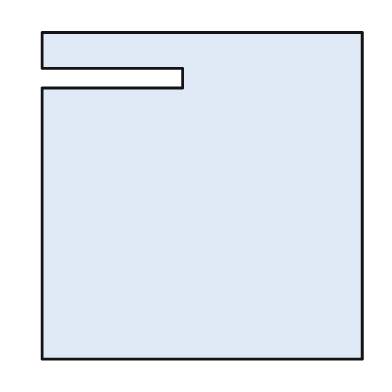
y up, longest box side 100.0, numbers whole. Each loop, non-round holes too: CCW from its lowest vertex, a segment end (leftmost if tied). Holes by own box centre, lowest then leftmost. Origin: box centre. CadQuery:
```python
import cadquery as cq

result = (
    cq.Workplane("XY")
    .moveTo(-49.0, -50.0)
    .lineTo(49.0, -50.0)
    .lineTo(49.0, 50.0)
    .lineTo(-49.0, 50.0)
    .lineTo(-49.0, 39.0)
    .lineTo(-6.0, 39.0)
    .lineTo(-6.0, 33.0)
    .lineTo(-49.0, 33.0)
    .close()
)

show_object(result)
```